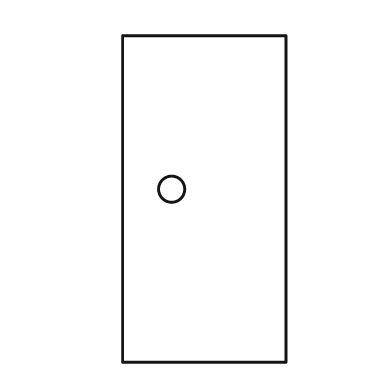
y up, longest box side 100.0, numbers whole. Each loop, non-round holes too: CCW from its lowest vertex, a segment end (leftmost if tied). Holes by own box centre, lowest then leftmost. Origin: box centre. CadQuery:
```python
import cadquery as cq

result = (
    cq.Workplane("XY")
    .moveTo(-25.0, -50.0)
    .lineTo(25.0, -50.0)
    .lineTo(25.0, 50.0)
    .lineTo(-25.0, 50.0)
    .close()
    .moveTo(-10.0, 3.0)
    .circle(4.0)
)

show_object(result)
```